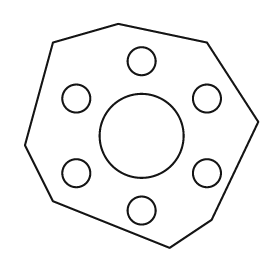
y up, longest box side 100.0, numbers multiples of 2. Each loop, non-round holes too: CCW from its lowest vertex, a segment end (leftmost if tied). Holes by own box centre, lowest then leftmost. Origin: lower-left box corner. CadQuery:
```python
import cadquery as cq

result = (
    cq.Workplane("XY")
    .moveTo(62.0, 0.0)
    .lineTo(80.0, 12.0)
    .lineTo(100.0, 54.0)
    .lineTo(78.0, 88.0)
    .lineTo(40.0, 96.0)
    .lineTo(12.0, 88.0)
    .lineTo(0.0, 44.0)
    .lineTo(12.0, 20.0)
    .close()
    .moveTo(50.0, 16.0)
    .circle(6.0)
    .moveTo(22.0, 32.0)
    .circle(6.0)
    .moveTo(78.0, 32.0)
    .circle(6.0)
    .moveTo(50.0, 48.0)
    .circle(18.0)
    .moveTo(22.0, 64.0)
    .circle(6.0)
    .moveTo(78.0, 64.0)
    .circle(6.0)
    .moveTo(50.0, 80.0)
    .circle(6.0)
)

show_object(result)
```